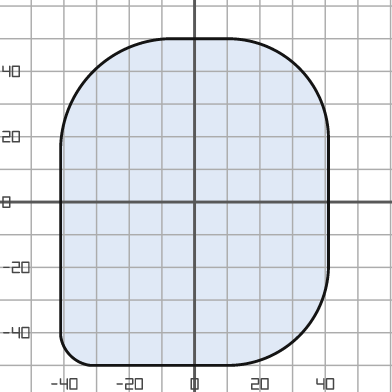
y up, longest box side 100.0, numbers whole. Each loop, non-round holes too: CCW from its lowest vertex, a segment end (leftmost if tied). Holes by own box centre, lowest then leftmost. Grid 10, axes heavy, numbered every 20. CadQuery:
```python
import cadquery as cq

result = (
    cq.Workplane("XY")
    .moveTo(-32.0, -50.0)
    .lineTo(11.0, -50.0)
    .threePointArc((32.0, -41.0), (41.0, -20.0))
    .lineTo(41.0, 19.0)
    .threePointArc((32.0, 41.0), (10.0, 50.0))
    .lineTo(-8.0, 50.0)
    .threePointArc((-31.0, 40.0), (-41.0, 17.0))
    .lineTo(-41.0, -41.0)
    .threePointArc((-38.0, -47.0), (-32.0, -50.0))
    .close()
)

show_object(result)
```